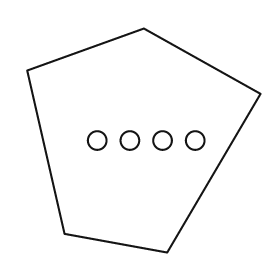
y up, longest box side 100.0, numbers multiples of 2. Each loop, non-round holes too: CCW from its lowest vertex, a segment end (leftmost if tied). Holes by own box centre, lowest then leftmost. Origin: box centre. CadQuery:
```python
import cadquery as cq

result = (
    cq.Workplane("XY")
    .moveTo(10.0, -48.0)
    .lineTo(50.0, 20.0)
    .lineTo(0.0, 48.0)
    .lineTo(-50.0, 30.0)
    .lineTo(-34.0, -40.0)
    .close()
    .moveTo(-20.0, 0.0)
    .circle(4.0)
    .moveTo(-6.0, 0.0)
    .circle(4.0)
    .moveTo(8.0, 0.0)
    .circle(4.0)
    .moveTo(22.0, 0.0)
    .circle(4.0)
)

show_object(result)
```